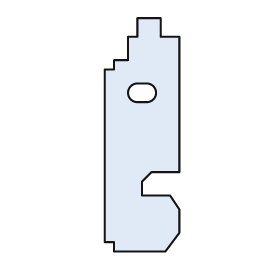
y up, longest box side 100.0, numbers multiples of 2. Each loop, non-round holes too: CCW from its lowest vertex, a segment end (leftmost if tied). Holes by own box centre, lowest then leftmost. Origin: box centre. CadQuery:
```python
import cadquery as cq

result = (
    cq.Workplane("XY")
    .moveTo(-12.0, -50.0)
    .lineTo(10.0, -50.0)
    .lineTo(16.0, -42.0)
    .lineTo(16.0, -32.0)
    .lineTo(12.0, -26.0)
    .lineTo(0.0, -26.0)
    .lineTo(0.0, -20.0)
    .lineTo(4.0, -16.0)
    .lineTo(16.0, -16.0)
    .lineTo(16.0, 42.0)
    .lineTo(8.0, 42.0)
    .lineTo(8.0, 50.0)
    .lineTo(-2.0, 50.0)
    .lineTo(-2.0, 42.0)
    .lineTo(-6.0, 42.0)
    .lineTo(-6.0, 32.0)
    .lineTo(-12.0, 32.0)
    .lineTo(-12.0, 28.0)
    .lineTo(-16.0, 28.0)
    .lineTo(-16.0, -46.0)
    .lineTo(-12.0, -46.0)
    .close()
    .moveTo(-2.0, 14.0)
    .lineTo(2.0, 14.0)
    .threePointArc((6.0, 18.0), (2.0, 22.0))
    .lineTo(-2.0, 22.0)
    .threePointArc((-6.0, 18.0), (-2.0, 14.0))
    .close()
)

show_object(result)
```